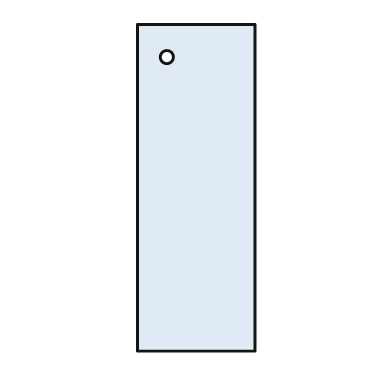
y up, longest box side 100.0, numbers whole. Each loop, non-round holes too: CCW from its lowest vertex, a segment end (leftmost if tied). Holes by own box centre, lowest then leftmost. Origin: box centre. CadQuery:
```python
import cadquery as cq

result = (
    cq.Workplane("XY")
    .moveTo(-18.0, -50.0)
    .lineTo(18.0, -50.0)
    .lineTo(18.0, 50.0)
    .lineTo(-18.0, 50.0)
    .close()
    .moveTo(-9.0, 40.0)
    .circle(2.0)
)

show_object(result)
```